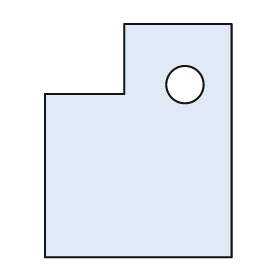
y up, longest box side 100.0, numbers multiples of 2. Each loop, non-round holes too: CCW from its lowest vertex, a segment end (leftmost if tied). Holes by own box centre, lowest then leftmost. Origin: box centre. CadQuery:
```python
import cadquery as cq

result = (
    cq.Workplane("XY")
    .moveTo(-40.0, -50.0)
    .lineTo(40.0, -50.0)
    .lineTo(40.0, 50.0)
    .lineTo(-6.0, 50.0)
    .lineTo(-6.0, 20.0)
    .lineTo(-40.0, 20.0)
    .close()
    .moveTo(20.0, 24.0)
    .circle(8.0)
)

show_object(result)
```